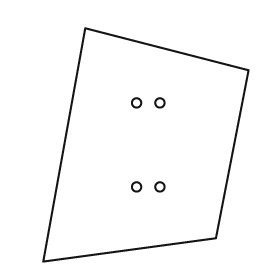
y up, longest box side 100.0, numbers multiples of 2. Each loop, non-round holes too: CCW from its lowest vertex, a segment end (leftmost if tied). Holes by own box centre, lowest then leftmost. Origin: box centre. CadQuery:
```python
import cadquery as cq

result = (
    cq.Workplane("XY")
    .moveTo(-44.0, -50.0)
    .lineTo(30.0, -40.0)
    .lineTo(44.0, 32.0)
    .lineTo(-26.0, 50.0)
    .close()
    .moveTo(-4.0, -18.0)
    .circle(2.0)
    .moveTo(6.0, -18.0)
    .circle(2.0)
    .moveTo(-4.0, 18.0)
    .circle(2.0)
    .moveTo(6.0, 18.0)
    .circle(2.0)
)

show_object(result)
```